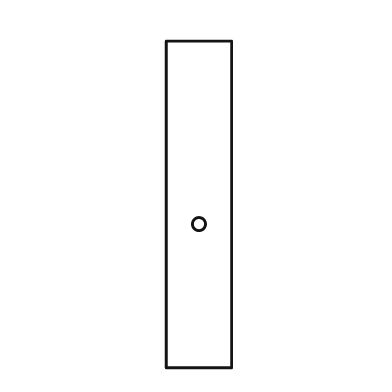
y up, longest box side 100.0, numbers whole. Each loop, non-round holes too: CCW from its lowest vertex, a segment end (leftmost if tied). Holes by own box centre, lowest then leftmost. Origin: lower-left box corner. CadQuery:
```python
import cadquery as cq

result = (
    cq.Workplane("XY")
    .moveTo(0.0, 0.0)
    .lineTo(20.0, 0.0)
    .lineTo(20.0, 100.0)
    .lineTo(0.0, 100.0)
    .close()
    .moveTo(10.0, 44.0)
    .circle(2.0)
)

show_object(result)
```